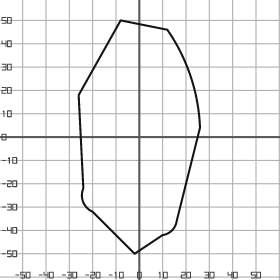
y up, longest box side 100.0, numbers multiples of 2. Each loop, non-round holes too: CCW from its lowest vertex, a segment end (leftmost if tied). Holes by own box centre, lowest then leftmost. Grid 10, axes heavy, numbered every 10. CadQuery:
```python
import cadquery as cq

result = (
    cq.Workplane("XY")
    .moveTo(-2.0, -50.0)
    .lineTo(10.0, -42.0)
    .threePointArc((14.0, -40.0), (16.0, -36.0))
    .lineTo(26.0, 4.0)
    .threePointArc((22.0, 26.0), (12.0, 46.0))
    .lineTo(-8.0, 50.0)
    .lineTo(-26.0, 18.0)
    .lineTo(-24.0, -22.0)
    .threePointArc((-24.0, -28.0), (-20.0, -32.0))
    .close()
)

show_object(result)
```